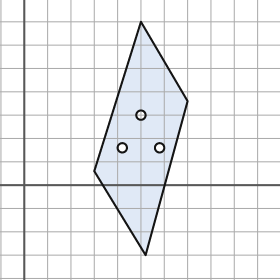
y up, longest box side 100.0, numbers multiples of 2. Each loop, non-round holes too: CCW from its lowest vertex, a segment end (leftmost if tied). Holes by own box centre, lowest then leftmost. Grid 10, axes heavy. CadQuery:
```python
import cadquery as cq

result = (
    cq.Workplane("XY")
    .moveTo(52.0, -30.0)
    .lineTo(70.0, 36.0)
    .lineTo(50.0, 70.0)
    .lineTo(30.0, 6.0)
    .close()
    .moveTo(42.0, 16.0)
    .circle(2.0)
    .moveTo(58.0, 16.0)
    .circle(2.0)
    .moveTo(50.0, 30.0)
    .circle(2.0)
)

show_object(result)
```